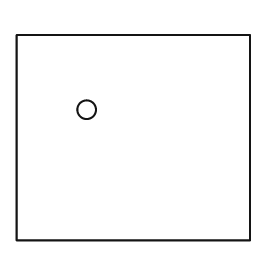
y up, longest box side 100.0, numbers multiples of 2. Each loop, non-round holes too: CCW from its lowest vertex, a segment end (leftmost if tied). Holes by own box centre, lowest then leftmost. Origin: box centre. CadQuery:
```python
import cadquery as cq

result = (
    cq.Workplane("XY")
    .moveTo(-50.0, -44.0)
    .lineTo(50.0, -44.0)
    .lineTo(50.0, 44.0)
    .lineTo(-50.0, 44.0)
    .close()
    .moveTo(-20.0, 12.0)
    .circle(4.0)
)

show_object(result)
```